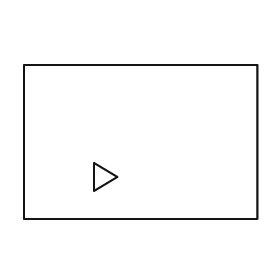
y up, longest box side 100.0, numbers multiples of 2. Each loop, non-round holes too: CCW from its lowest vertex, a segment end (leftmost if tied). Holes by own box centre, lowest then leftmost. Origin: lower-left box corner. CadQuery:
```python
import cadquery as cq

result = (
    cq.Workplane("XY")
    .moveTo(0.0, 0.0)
    .lineTo(100.0, 0.0)
    .lineTo(100.0, 66.0)
    .lineTo(0.0, 66.0)
    .close()
    .moveTo(30.0, 12.0)
    .lineTo(40.0, 18.0)
    .lineTo(30.0, 24.0)
    .close()
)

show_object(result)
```